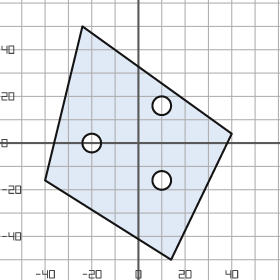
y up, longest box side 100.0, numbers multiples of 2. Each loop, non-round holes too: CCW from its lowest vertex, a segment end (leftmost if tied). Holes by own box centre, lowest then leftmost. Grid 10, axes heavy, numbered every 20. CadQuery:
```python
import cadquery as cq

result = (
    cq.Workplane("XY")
    .moveTo(14.0, -50.0)
    .lineTo(40.0, 4.0)
    .lineTo(-24.0, 50.0)
    .lineTo(-40.0, -16.0)
    .close()
    .moveTo(10.0, -16.0)
    .circle(4.0)
    .moveTo(-20.0, 0.0)
    .circle(4.0)
    .moveTo(10.0, 16.0)
    .circle(4.0)
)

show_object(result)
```